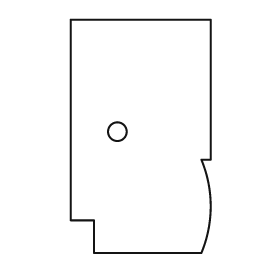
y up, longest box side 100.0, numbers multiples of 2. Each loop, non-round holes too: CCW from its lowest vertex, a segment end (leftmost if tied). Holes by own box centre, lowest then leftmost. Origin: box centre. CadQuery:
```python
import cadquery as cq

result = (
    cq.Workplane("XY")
    .moveTo(-20.0, -50.0)
    .lineTo(26.0, -50.0)
    .threePointArc((30.0, -30.0), (26.0, -10.0))
    .lineTo(30.0, -10.0)
    .lineTo(30.0, 50.0)
    .lineTo(-30.0, 50.0)
    .lineTo(-30.0, -36.0)
    .lineTo(-20.0, -36.0)
    .close()
    .moveTo(-10.0, 2.0)
    .circle(4.0)
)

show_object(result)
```